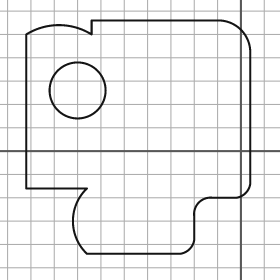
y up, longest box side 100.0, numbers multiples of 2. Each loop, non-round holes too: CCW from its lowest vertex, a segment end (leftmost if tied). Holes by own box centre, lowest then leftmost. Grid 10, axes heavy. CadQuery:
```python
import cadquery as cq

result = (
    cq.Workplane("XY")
    .moveTo(-66.0, -44.0)
    .lineTo(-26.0, -44.0)
    .threePointArc((-22.0, -42.0), (-20.0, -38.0))
    .lineTo(-20.0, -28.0)
    .threePointArc((-18.0, -22.0), (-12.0, -20.0))
    .lineTo(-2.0, -20.0)
    .threePointArc((2.0, -18.0), (4.0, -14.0))
    .lineTo(4.0, 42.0)
    .threePointArc((0.0, 52.0), (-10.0, 56.0))
    .lineTo(-64.0, 56.0)
    .lineTo(-64.0, 50.0)
    .threePointArc((-78.0, 54.0), (-92.0, 50.0))
    .lineTo(-92.0, -16.0)
    .lineTo(-66.0, -16.0)
    .threePointArc((-72.0, -30.0), (-66.0, -44.0))
    .close()
    .moveTo(-70.0, 26.0)
    .circle(12.0)
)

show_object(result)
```